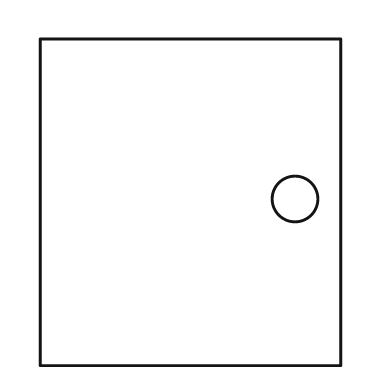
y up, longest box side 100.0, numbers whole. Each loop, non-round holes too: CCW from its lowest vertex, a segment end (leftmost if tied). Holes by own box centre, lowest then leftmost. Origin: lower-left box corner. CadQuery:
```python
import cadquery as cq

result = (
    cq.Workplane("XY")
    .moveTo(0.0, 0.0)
    .lineTo(92.0, 0.0)
    .lineTo(92.0, 100.0)
    .lineTo(0.0, 100.0)
    .close()
    .moveTo(78.0, 51.0)
    .circle(7.0)
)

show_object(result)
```